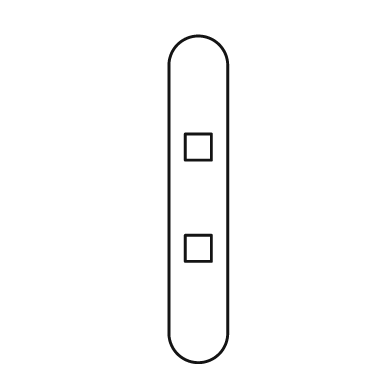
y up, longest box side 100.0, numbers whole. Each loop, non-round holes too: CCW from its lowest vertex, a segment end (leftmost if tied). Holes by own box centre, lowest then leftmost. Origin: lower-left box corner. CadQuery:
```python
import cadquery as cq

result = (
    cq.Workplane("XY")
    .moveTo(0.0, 9.0)
    .threePointArc((9.0, 0.0), (18.0, 9.0))
    .lineTo(18.0, 91.0)
    .threePointArc((9.0, 100.0), (0.0, 91.0))
    .close()
    .moveTo(5.0, 31.0)
    .lineTo(13.0, 31.0)
    .lineTo(13.0, 39.0)
    .lineTo(5.0, 39.0)
    .close()
    .moveTo(5.0, 62.0)
    .lineTo(13.0, 62.0)
    .lineTo(13.0, 70.0)
    .lineTo(5.0, 70.0)
    .close()
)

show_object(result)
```